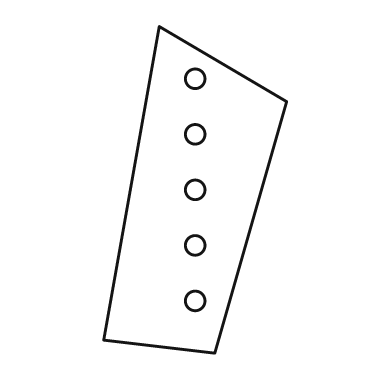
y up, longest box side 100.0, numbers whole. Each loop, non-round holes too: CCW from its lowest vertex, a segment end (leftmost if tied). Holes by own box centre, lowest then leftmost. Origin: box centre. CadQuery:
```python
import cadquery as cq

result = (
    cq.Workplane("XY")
    .moveTo(6.0, -50.0)
    .lineTo(28.0, 27.0)
    .lineTo(-11.0, 50.0)
    .lineTo(-28.0, -46.0)
    .close()
    .moveTo(0.0, -34.0)
    .circle(3.0)
    .moveTo(0.0, -17.0)
    .circle(3.0)
    .moveTo(0.0, 0.0)
    .circle(3.0)
    .moveTo(0.0, 17.0)
    .circle(3.0)
    .moveTo(0.0, 34.0)
    .circle(3.0)
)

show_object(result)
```